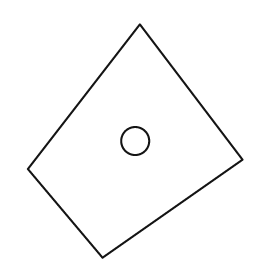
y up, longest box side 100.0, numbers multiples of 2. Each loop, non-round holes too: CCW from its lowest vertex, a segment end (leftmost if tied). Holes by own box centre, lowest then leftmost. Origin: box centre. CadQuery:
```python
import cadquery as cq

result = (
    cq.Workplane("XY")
    .moveTo(-14.0, -50.0)
    .lineTo(46.0, -8.0)
    .lineTo(2.0, 50.0)
    .lineTo(-46.0, -12.0)
    .close()
    .moveTo(0.0, 0.0)
    .circle(6.0)
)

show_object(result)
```